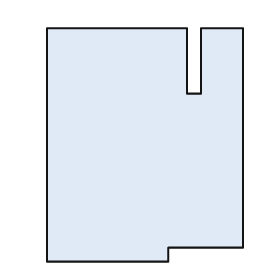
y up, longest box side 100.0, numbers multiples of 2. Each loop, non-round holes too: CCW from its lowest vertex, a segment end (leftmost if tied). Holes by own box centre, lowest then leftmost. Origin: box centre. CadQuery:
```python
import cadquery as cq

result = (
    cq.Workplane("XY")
    .moveTo(-42.0, -50.0)
    .lineTo(10.0, -50.0)
    .lineTo(10.0, -44.0)
    .lineTo(42.0, -44.0)
    .lineTo(42.0, 50.0)
    .lineTo(24.0, 50.0)
    .lineTo(24.0, 22.0)
    .lineTo(18.0, 22.0)
    .lineTo(18.0, 50.0)
    .lineTo(-42.0, 50.0)
    .close()
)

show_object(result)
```